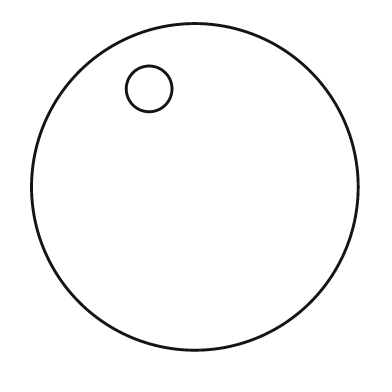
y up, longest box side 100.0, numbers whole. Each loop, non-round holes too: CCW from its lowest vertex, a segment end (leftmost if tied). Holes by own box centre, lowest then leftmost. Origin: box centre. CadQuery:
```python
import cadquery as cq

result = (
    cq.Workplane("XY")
    .moveTo(0.0, 0.0)
    .circle(50.0)
    .moveTo(-14.0, 30.0)
    .circle(7.0)
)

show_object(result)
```